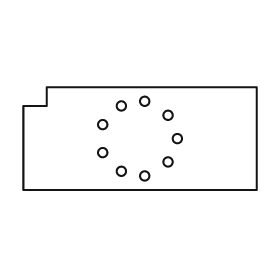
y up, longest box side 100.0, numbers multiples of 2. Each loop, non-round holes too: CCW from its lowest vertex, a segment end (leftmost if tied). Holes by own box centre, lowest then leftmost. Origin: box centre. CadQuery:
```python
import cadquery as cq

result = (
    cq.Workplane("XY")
    .moveTo(-50.0, -22.0)
    .lineTo(50.0, -22.0)
    .lineTo(50.0, 22.0)
    .lineTo(-40.0, 22.0)
    .lineTo(-40.0, 14.0)
    .lineTo(-50.0, 14.0)
    .close()
    .moveTo(2.0, -16.0)
    .circle(2.0)
    .moveTo(-8.0, -14.0)
    .circle(2.0)
    .moveTo(12.0, -10.0)
    .circle(2.0)
    .moveTo(-16.0, -6.0)
    .circle(2.0)
    .moveTo(16.0, 0.0)
    .circle(2.0)
    .moveTo(-16.0, 6.0)
    .circle(2.0)
    .moveTo(12.0, 10.0)
    .circle(2.0)
    .moveTo(-8.0, 14.0)
    .circle(2.0)
    .moveTo(2.0, 16.0)
    .circle(2.0)
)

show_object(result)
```